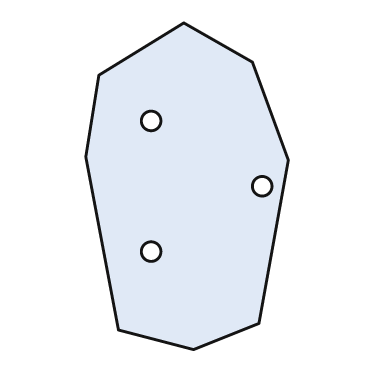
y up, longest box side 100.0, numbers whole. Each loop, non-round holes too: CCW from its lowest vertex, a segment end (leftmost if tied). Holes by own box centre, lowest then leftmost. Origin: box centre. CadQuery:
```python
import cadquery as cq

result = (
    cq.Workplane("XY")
    .moveTo(2.0, -50.0)
    .lineTo(22.0, -42.0)
    .lineTo(31.0, 8.0)
    .lineTo(20.0, 38.0)
    .lineTo(-1.0, 50.0)
    .lineTo(-27.0, 34.0)
    .lineTo(-31.0, 9.0)
    .lineTo(-21.0, -44.0)
    .close()
    .moveTo(-11.0, -20.0)
    .circle(3.0)
    .moveTo(23.0, 0.0)
    .circle(3.0)
    .moveTo(-11.0, 20.0)
    .circle(3.0)
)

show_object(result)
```